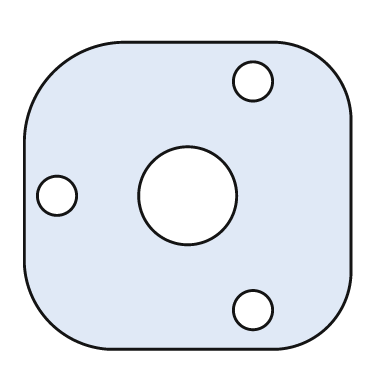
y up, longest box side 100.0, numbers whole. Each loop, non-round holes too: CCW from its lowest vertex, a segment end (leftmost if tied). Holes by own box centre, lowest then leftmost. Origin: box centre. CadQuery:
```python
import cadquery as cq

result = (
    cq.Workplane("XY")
    .moveTo(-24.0, -47.0)
    .lineTo(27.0, -47.0)
    .threePointArc((43.0, -40.0), (50.0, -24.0))
    .lineTo(50.0, 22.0)
    .threePointArc((43.0, 40.0), (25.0, 47.0))
    .lineTo(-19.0, 47.0)
    .threePointArc((-41.0, 38.0), (-50.0, 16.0))
    .lineTo(-50.0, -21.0)
    .threePointArc((-42.0, -39.0), (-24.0, -47.0))
    .close()
    .moveTo(20.0, -35.0)
    .circle(6.0)
    .moveTo(-40.0, 0.0)
    .circle(6.0)
    .moveTo(0.0, 0.0)
    .circle(15.0)
    .moveTo(20.0, 35.0)
    .circle(6.0)
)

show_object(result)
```